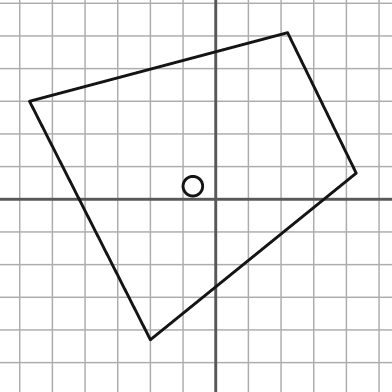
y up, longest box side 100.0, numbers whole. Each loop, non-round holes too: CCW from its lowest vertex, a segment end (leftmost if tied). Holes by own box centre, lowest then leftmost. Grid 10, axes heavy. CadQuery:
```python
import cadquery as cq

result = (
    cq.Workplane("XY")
    .moveTo(-20.0, -43.0)
    .lineTo(43.0, 8.0)
    .lineTo(22.0, 51.0)
    .lineTo(-57.0, 30.0)
    .close()
    .moveTo(-7.0, 4.0)
    .circle(3.0)
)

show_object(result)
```